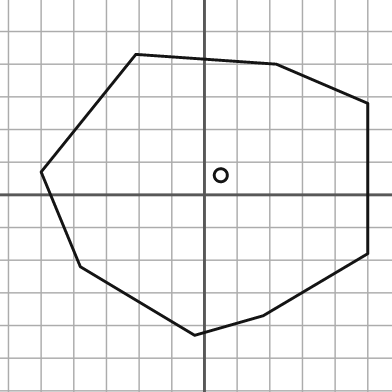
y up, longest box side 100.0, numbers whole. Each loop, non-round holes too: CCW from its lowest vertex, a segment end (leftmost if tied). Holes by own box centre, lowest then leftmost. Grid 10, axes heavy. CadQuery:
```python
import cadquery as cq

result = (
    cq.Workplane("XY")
    .moveTo(-3.0, -43.0)
    .lineTo(18.0, -37.0)
    .lineTo(50.0, -18.0)
    .lineTo(50.0, 28.0)
    .lineTo(22.0, 40.0)
    .lineTo(-21.0, 43.0)
    .lineTo(-50.0, 7.0)
    .lineTo(-38.0, -22.0)
    .close()
    .moveTo(5.0, 6.0)
    .circle(2.0)
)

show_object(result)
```